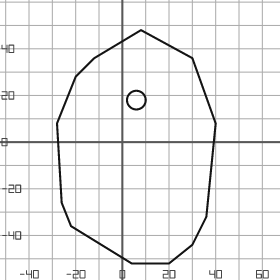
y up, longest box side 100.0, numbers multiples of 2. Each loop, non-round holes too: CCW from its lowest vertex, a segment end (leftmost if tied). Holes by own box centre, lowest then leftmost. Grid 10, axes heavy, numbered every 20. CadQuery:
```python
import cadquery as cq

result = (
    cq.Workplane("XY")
    .moveTo(4.0, -52.0)
    .lineTo(20.0, -52.0)
    .lineTo(30.0, -44.0)
    .lineTo(36.0, -32.0)
    .lineTo(40.0, 8.0)
    .lineTo(30.0, 36.0)
    .lineTo(8.0, 48.0)
    .lineTo(-12.0, 36.0)
    .lineTo(-20.0, 28.0)
    .lineTo(-28.0, 8.0)
    .lineTo(-26.0, -26.0)
    .lineTo(-22.0, -36.0)
    .close()
    .moveTo(6.0, 18.0)
    .circle(4.0)
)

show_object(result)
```